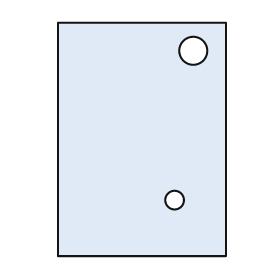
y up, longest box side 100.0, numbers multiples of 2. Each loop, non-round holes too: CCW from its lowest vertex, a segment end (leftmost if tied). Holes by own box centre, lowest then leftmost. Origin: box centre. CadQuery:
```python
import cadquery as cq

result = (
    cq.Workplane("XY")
    .moveTo(-36.0, -50.0)
    .lineTo(36.0, -50.0)
    .lineTo(36.0, 50.0)
    .lineTo(-36.0, 50.0)
    .close()
    .moveTo(14.0, -26.0)
    .circle(4.0)
    .moveTo(22.0, 38.0)
    .circle(6.0)
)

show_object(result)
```